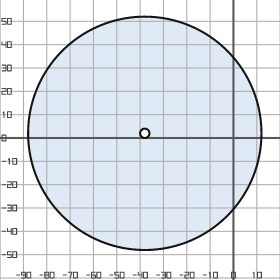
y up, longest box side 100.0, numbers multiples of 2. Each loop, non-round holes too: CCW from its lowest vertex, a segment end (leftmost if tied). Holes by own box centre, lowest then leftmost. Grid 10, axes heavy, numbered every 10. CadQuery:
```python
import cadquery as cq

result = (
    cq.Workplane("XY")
    .moveTo(-38.0, 2.0)
    .circle(50.0)
    .moveTo(-38.0, 2.0)
    .circle(2.0)
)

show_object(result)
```